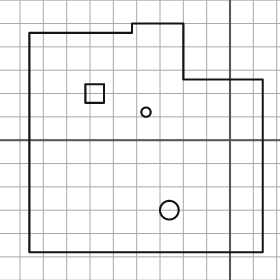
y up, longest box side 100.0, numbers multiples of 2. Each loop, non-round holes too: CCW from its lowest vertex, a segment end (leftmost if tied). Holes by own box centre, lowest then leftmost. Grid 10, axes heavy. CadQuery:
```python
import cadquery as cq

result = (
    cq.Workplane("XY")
    .moveTo(-86.0, -48.0)
    .lineTo(14.0, -48.0)
    .lineTo(14.0, 26.0)
    .lineTo(-20.0, 26.0)
    .lineTo(-20.0, 50.0)
    .lineTo(-42.0, 50.0)
    .lineTo(-42.0, 46.0)
    .lineTo(-86.0, 46.0)
    .close()
    .moveTo(-26.0, -30.0)
    .circle(4.0)
    .moveTo(-36.0, 12.0)
    .circle(2.0)
    .moveTo(-62.0, 16.0)
    .lineTo(-54.0, 16.0)
    .lineTo(-54.0, 24.0)
    .lineTo(-62.0, 24.0)
    .close()
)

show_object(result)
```